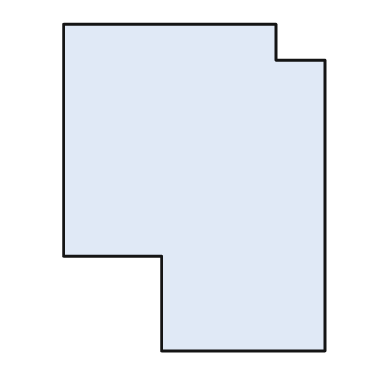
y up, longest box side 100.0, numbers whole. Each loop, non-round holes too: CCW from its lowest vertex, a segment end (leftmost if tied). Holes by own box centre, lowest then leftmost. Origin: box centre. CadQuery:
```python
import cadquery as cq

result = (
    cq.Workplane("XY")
    .moveTo(-10.0, -50.0)
    .lineTo(40.0, -50.0)
    .lineTo(40.0, 39.0)
    .lineTo(25.0, 39.0)
    .lineTo(25.0, 50.0)
    .lineTo(-40.0, 50.0)
    .lineTo(-40.0, -21.0)
    .lineTo(-10.0, -21.0)
    .close()
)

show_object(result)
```